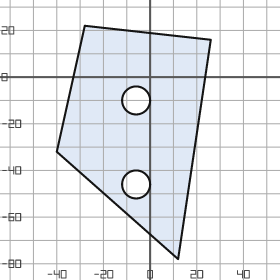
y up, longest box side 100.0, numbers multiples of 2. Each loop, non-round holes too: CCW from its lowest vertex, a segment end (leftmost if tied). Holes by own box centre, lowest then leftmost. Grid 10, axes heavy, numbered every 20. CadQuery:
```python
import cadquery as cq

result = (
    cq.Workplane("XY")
    .moveTo(12.0, -78.0)
    .lineTo(26.0, 16.0)
    .lineTo(-28.0, 22.0)
    .lineTo(-40.0, -32.0)
    .close()
    .moveTo(-6.0, -46.0)
    .circle(6.0)
    .moveTo(-6.0, -10.0)
    .circle(6.0)
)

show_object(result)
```